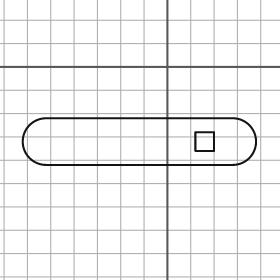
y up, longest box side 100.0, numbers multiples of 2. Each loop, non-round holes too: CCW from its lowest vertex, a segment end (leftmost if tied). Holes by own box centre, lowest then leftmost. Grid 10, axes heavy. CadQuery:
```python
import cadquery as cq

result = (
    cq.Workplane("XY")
    .moveTo(-52.0, -42.0)
    .lineTo(28.0, -42.0)
    .threePointArc((38.0, -32.0), (28.0, -22.0))
    .lineTo(-52.0, -22.0)
    .threePointArc((-62.0, -32.0), (-52.0, -42.0))
    .close()
    .moveTo(12.0, -36.0)
    .lineTo(20.0, -36.0)
    .lineTo(20.0, -28.0)
    .lineTo(12.0, -28.0)
    .close()
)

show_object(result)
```